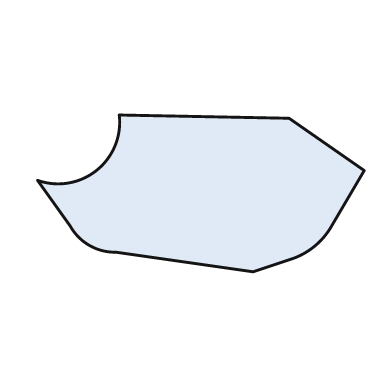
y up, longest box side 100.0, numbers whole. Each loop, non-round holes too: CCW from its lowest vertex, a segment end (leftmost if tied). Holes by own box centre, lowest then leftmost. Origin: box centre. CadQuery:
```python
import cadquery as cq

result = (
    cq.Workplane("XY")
    .moveTo(16.0, -24.0)
    .lineTo(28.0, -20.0)
    .threePointArc((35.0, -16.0), (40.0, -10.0))
    .lineTo(50.0, 7.0)
    .lineTo(27.0, 23.0)
    .lineTo(-25.0, 24.0)
    .threePointArc((-32.0, 7.0), (-50.0, 4.0))
    .lineTo(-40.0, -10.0)
    .threePointArc((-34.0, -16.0), (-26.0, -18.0))
    .close()
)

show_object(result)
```